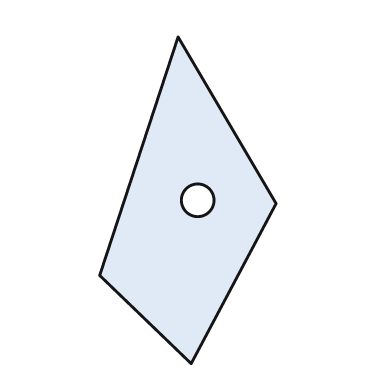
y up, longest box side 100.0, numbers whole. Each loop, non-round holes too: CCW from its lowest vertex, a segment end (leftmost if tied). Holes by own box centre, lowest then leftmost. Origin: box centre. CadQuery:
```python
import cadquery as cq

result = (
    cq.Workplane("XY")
    .moveTo(1.0, -50.0)
    .lineTo(27.0, -1.0)
    .lineTo(-3.0, 50.0)
    .lineTo(-27.0, -23.0)
    .close()
    .moveTo(3.0, 0.0)
    .circle(5.0)
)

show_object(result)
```